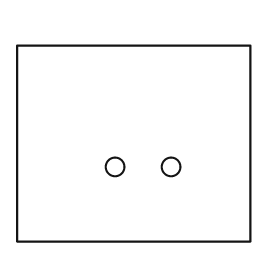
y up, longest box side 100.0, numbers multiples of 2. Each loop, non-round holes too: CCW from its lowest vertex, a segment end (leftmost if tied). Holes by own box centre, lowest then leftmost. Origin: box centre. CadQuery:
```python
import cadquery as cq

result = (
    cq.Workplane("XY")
    .moveTo(-50.0, -42.0)
    .lineTo(50.0, -42.0)
    .lineTo(50.0, 42.0)
    .lineTo(-50.0, 42.0)
    .close()
    .moveTo(-8.0, -10.0)
    .circle(4.0)
    .moveTo(16.0, -10.0)
    .circle(4.0)
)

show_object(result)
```